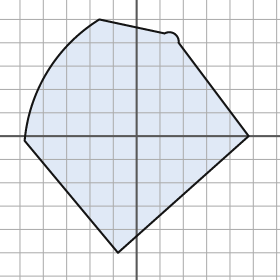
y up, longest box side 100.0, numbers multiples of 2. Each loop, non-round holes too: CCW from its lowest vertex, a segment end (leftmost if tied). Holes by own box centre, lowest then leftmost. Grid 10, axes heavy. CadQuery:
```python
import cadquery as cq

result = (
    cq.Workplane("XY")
    .moveTo(-8.0, -50.0)
    .lineTo(48.0, 0.0)
    .lineTo(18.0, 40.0)
    .threePointArc((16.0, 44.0), (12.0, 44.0))
    .lineTo(-16.0, 50.0)
    .threePointArc((-38.0, 28.0), (-48.0, -2.0))
    .close()
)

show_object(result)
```